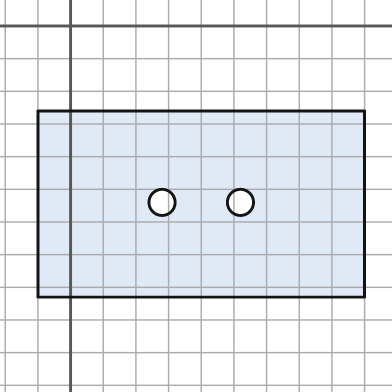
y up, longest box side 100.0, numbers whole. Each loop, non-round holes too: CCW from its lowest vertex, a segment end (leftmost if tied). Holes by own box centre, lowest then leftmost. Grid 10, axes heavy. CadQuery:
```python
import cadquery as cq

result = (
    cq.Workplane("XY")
    .moveTo(-10.0, -83.0)
    .lineTo(90.0, -83.0)
    .lineTo(90.0, -26.0)
    .lineTo(-10.0, -26.0)
    .close()
    .moveTo(28.0, -54.0)
    .circle(4.0)
    .moveTo(52.0, -54.0)
    .circle(4.0)
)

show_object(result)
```